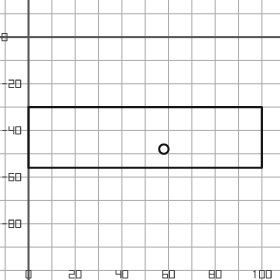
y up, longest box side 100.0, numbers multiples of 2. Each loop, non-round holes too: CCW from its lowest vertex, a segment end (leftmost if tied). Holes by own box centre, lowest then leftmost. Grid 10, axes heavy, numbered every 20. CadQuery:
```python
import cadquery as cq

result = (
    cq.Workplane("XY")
    .moveTo(0.0, -56.0)
    .lineTo(100.0, -56.0)
    .lineTo(100.0, -30.0)
    .lineTo(0.0, -30.0)
    .close()
    .moveTo(58.0, -48.0)
    .circle(2.0)
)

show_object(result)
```